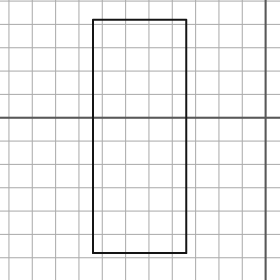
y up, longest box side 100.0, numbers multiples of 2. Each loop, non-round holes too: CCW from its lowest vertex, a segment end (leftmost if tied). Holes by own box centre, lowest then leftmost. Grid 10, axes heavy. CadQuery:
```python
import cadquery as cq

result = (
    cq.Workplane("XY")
    .moveTo(-74.0, -58.0)
    .lineTo(-34.0, -58.0)
    .lineTo(-34.0, 42.0)
    .lineTo(-74.0, 42.0)
    .close()
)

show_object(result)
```